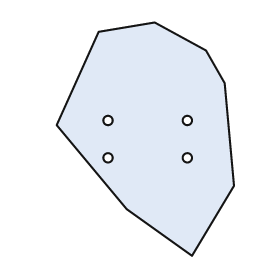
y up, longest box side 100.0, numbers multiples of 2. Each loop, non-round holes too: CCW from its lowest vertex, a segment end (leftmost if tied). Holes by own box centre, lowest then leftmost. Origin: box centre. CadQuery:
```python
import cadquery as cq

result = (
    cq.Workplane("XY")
    .moveTo(20.0, -50.0)
    .lineTo(38.0, -20.0)
    .lineTo(34.0, 24.0)
    .lineTo(26.0, 38.0)
    .lineTo(4.0, 50.0)
    .lineTo(-20.0, 46.0)
    .lineTo(-38.0, 6.0)
    .lineTo(-8.0, -30.0)
    .close()
    .moveTo(-16.0, -8.0)
    .circle(2.0)
    .moveTo(18.0, -8.0)
    .circle(2.0)
    .moveTo(-16.0, 8.0)
    .circle(2.0)
    .moveTo(18.0, 8.0)
    .circle(2.0)
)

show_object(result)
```